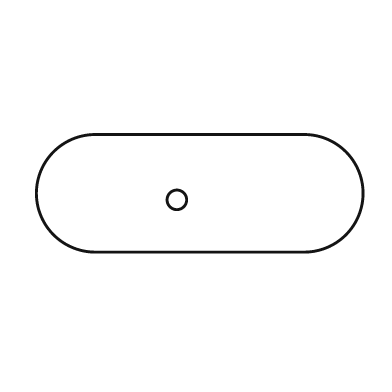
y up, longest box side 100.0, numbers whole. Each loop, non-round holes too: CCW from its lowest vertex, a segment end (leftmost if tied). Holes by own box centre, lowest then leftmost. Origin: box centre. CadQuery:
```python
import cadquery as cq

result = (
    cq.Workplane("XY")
    .moveTo(-32.0, -18.0)
    .lineTo(32.0, -18.0)
    .threePointArc((50.0, 0.0), (32.0, 18.0))
    .lineTo(-32.0, 18.0)
    .threePointArc((-50.0, 0.0), (-32.0, -18.0))
    .close()
    .moveTo(-7.0, -2.0)
    .circle(3.0)
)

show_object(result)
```